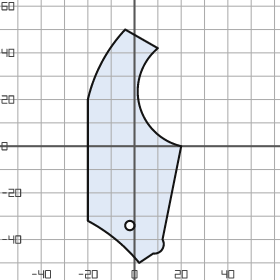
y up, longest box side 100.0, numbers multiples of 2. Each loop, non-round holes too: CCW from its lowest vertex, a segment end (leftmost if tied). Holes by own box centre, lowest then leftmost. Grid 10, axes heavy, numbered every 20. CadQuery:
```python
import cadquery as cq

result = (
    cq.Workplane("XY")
    .moveTo(2.0, -50.0)
    .lineTo(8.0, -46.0)
    .threePointArc((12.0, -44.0), (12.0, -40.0))
    .lineTo(20.0, 0.0)
    .threePointArc((2.0, 18.0), (10.0, 42.0))
    .lineTo(-4.0, 50.0)
    .threePointArc((-14.0, 36.0), (-20.0, 20.0))
    .lineTo(-20.0, -32.0)
    .threePointArc((-8.0, -40.0), (2.0, -50.0))
    .close()
    .moveTo(-2.0, -34.0)
    .circle(2.0)
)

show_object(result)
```